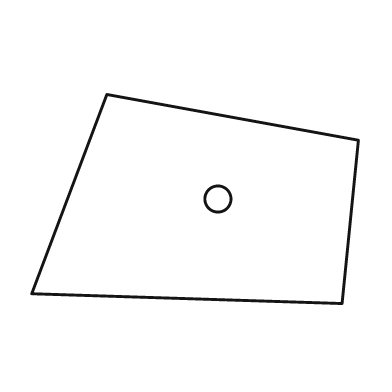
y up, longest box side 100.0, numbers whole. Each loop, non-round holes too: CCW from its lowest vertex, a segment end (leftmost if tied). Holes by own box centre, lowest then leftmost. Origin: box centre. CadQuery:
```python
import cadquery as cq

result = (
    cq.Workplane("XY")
    .moveTo(45.0, -32.0)
    .lineTo(50.0, 18.0)
    .lineTo(-27.0, 32.0)
    .lineTo(-50.0, -29.0)
    .close()
    .moveTo(7.0, 0.0)
    .circle(4.0)
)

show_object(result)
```